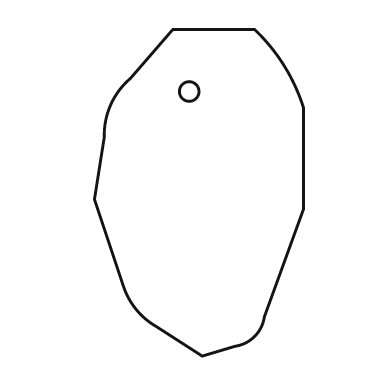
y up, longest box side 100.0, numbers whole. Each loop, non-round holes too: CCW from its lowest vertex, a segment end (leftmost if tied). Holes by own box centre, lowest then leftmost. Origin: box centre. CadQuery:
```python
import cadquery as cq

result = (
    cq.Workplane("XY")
    .moveTo(1.0, -50.0)
    .lineTo(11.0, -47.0)
    .threePointArc((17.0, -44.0), (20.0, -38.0))
    .lineTo(32.0, -5.0)
    .lineTo(32.0, 26.0)
    .threePointArc((26.0, 39.0), (17.0, 50.0))
    .lineTo(-8.0, 50.0)
    .lineTo(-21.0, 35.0)
    .threePointArc((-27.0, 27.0), (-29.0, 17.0))
    .lineTo(-32.0, -2.0)
    .lineTo(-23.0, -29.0)
    .threePointArc((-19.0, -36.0), (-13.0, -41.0))
    .close()
    .moveTo(-3.0, 31.0)
    .circle(3.0)
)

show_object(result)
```